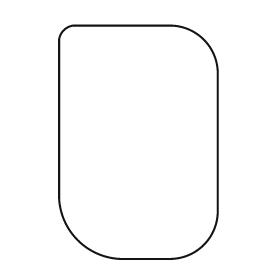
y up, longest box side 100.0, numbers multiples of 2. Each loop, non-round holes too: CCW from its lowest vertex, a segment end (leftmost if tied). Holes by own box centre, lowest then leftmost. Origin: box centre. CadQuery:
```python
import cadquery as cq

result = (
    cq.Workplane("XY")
    .moveTo(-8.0, -50.0)
    .lineTo(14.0, -50.0)
    .threePointArc((28.0, -44.0), (34.0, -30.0))
    .lineTo(34.0, 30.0)
    .threePointArc((28.0, 44.0), (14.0, 50.0))
    .lineTo(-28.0, 50.0)
    .threePointArc((-32.0, 48.0), (-34.0, 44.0))
    .lineTo(-34.0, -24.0)
    .threePointArc((-26.0, -42.0), (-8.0, -50.0))
    .close()
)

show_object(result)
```